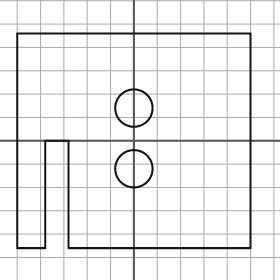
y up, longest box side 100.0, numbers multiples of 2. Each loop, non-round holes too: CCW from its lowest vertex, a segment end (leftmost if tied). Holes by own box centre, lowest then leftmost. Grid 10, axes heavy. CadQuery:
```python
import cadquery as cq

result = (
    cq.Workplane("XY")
    .moveTo(-50.0, -46.0)
    .lineTo(-38.0, -46.0)
    .lineTo(-38.0, 0.0)
    .lineTo(-28.0, 0.0)
    .lineTo(-28.0, -46.0)
    .lineTo(50.0, -46.0)
    .lineTo(50.0, 46.0)
    .lineTo(-50.0, 46.0)
    .close()
    .moveTo(0.0, -12.0)
    .circle(8.0)
    .moveTo(0.0, 14.0)
    .circle(8.0)
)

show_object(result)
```